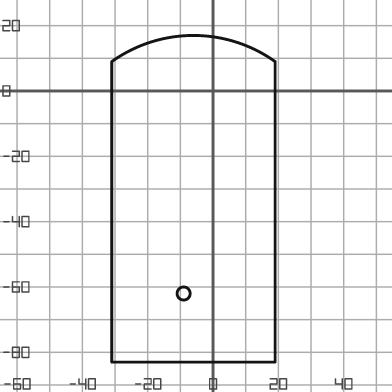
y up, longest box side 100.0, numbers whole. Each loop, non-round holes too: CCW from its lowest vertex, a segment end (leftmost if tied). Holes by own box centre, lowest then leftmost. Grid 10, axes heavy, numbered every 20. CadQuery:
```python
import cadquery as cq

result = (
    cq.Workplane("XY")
    .moveTo(-31.0, -83.0)
    .lineTo(19.0, -83.0)
    .lineTo(19.0, 9.0)
    .threePointArc((-6.0, 17.0), (-31.0, 9.0))
    .close()
    .moveTo(-9.0, -62.0)
    .circle(2.0)
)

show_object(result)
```